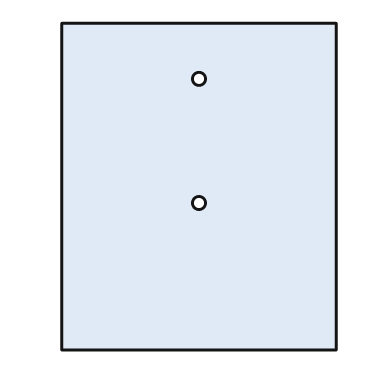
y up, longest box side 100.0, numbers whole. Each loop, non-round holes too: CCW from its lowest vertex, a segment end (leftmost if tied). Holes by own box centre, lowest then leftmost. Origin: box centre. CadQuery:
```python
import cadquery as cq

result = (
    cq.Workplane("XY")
    .moveTo(-42.0, -50.0)
    .lineTo(42.0, -50.0)
    .lineTo(42.0, 50.0)
    .lineTo(-42.0, 50.0)
    .close()
    .moveTo(0.0, -5.0)
    .circle(2.0)
    .moveTo(0.0, 33.0)
    .circle(2.0)
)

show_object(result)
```